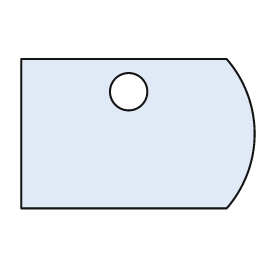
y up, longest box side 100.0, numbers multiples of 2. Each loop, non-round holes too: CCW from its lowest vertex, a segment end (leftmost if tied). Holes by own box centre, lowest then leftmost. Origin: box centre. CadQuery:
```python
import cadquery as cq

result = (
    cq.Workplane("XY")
    .moveTo(-50.0, -32.0)
    .lineTo(38.0, -32.0)
    .threePointArc((50.0, 0.0), (38.0, 32.0))
    .lineTo(-50.0, 32.0)
    .close()
    .moveTo(-4.0, 18.0)
    .circle(8.0)
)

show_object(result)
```